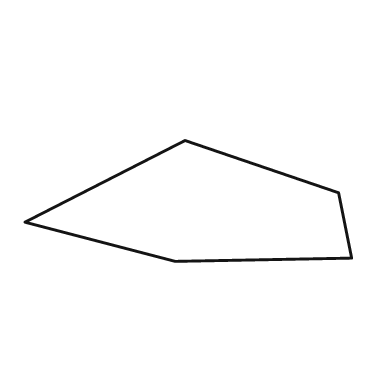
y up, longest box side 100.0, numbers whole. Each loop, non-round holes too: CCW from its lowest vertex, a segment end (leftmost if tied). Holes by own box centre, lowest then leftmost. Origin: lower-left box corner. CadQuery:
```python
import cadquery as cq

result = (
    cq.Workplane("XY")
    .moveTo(46.0, 0.0)
    .lineTo(100.0, 1.0)
    .lineTo(96.0, 21.0)
    .lineTo(49.0, 37.0)
    .lineTo(0.0, 12.0)
    .close()
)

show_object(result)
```